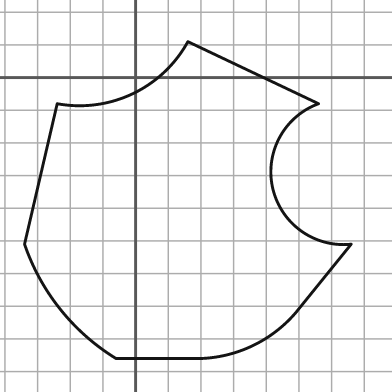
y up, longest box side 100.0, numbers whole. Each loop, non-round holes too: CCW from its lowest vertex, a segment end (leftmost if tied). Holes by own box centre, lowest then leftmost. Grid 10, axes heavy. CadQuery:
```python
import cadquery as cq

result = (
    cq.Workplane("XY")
    .moveTo(-6.0, -86.0)
    .lineTo(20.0, -86.0)
    .threePointArc((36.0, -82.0), (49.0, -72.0))
    .lineTo(66.0, -51.0)
    .threePointArc((42.0, -34.0), (56.0, -8.0))
    .lineTo(16.0, 11.0)
    .threePointArc((-1.0, -5.0), (-24.0, -8.0))
    .lineTo(-34.0, -51.0)
    .threePointArc((-23.0, -71.0), (-6.0, -86.0))
    .close()
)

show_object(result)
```